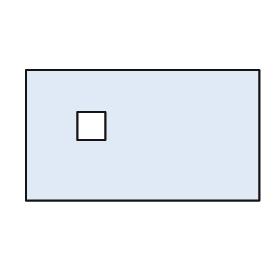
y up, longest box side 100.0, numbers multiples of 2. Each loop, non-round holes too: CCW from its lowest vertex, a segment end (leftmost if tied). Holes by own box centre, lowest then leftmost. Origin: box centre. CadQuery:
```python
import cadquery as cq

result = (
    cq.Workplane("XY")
    .moveTo(-50.0, -28.0)
    .lineTo(50.0, -28.0)
    .lineTo(50.0, 28.0)
    .lineTo(-50.0, 28.0)
    .close()
    .moveTo(-28.0, -2.0)
    .lineTo(-16.0, -2.0)
    .lineTo(-16.0, 10.0)
    .lineTo(-28.0, 10.0)
    .close()
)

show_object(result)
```